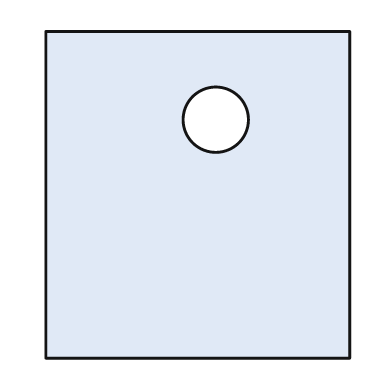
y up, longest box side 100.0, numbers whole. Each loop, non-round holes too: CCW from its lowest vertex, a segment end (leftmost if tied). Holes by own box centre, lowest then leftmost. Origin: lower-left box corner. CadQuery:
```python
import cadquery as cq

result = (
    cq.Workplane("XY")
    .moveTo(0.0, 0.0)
    .lineTo(93.0, 0.0)
    .lineTo(93.0, 100.0)
    .lineTo(0.0, 100.0)
    .close()
    .moveTo(52.0, 73.0)
    .circle(10.0)
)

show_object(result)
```